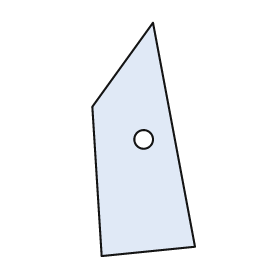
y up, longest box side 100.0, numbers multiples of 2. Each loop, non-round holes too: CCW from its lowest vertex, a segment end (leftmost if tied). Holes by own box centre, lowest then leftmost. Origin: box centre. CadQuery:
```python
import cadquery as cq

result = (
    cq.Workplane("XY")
    .moveTo(-18.0, -50.0)
    .lineTo(22.0, -46.0)
    .lineTo(4.0, 50.0)
    .lineTo(-22.0, 14.0)
    .close()
    .moveTo(0.0, 0.0)
    .circle(4.0)
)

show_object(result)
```